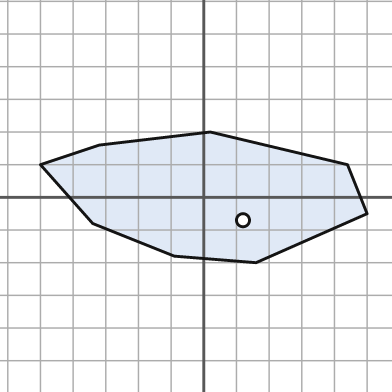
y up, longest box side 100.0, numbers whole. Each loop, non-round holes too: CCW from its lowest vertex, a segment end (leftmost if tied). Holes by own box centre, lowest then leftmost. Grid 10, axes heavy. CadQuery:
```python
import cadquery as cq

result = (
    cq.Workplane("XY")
    .moveTo(16.0, -20.0)
    .lineTo(50.0, -5.0)
    .lineTo(44.0, 10.0)
    .lineTo(2.0, 20.0)
    .lineTo(-32.0, 16.0)
    .lineTo(-50.0, 10.0)
    .lineTo(-34.0, -8.0)
    .lineTo(-9.0, -18.0)
    .close()
    .moveTo(12.0, -7.0)
    .circle(2.0)
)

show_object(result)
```